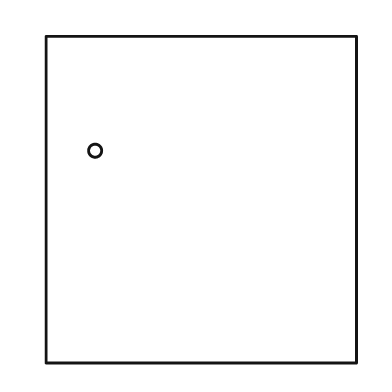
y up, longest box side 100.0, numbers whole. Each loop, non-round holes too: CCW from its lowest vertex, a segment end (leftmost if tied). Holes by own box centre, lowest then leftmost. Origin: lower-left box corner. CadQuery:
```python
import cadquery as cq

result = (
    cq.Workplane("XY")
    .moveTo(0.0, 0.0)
    .lineTo(95.0, 0.0)
    .lineTo(95.0, 100.0)
    .lineTo(0.0, 100.0)
    .close()
    .moveTo(15.0, 65.0)
    .circle(2.0)
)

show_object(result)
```